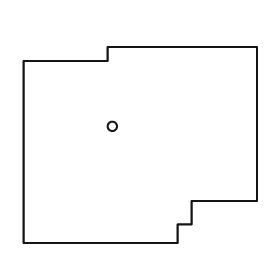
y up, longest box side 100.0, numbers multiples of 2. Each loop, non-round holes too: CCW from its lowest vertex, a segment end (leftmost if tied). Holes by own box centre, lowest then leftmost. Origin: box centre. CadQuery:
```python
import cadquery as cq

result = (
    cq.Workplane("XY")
    .moveTo(-50.0, -42.0)
    .lineTo(16.0, -42.0)
    .lineTo(16.0, -34.0)
    .lineTo(22.0, -34.0)
    .lineTo(22.0, -24.0)
    .lineTo(50.0, -24.0)
    .lineTo(50.0, 42.0)
    .lineTo(-14.0, 42.0)
    .lineTo(-14.0, 36.0)
    .lineTo(-50.0, 36.0)
    .close()
    .moveTo(-12.0, 8.0)
    .circle(2.0)
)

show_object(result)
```